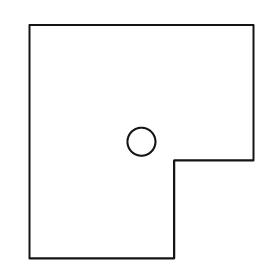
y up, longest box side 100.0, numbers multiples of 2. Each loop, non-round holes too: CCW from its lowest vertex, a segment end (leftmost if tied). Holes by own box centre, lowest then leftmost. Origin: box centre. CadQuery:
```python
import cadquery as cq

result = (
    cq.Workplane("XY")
    .moveTo(-48.0, -50.0)
    .lineTo(14.0, -50.0)
    .lineTo(14.0, -8.0)
    .lineTo(48.0, -8.0)
    .lineTo(48.0, 50.0)
    .lineTo(-48.0, 50.0)
    .close()
    .moveTo(0.0, 0.0)
    .circle(6.0)
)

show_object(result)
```